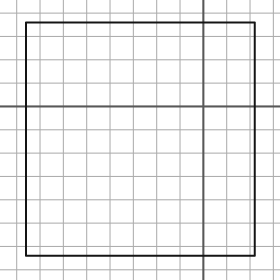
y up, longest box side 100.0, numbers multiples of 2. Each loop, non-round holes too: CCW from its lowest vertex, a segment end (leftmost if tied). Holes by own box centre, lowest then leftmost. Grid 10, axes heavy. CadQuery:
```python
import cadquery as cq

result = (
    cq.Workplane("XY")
    .moveTo(-76.0, -64.0)
    .lineTo(22.0, -64.0)
    .lineTo(22.0, 36.0)
    .lineTo(-76.0, 36.0)
    .close()
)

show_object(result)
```